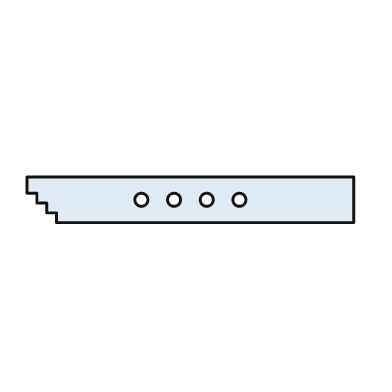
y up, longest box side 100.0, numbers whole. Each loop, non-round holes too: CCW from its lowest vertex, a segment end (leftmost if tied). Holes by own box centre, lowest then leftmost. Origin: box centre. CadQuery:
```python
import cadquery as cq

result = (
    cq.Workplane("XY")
    .moveTo(-41.0, -7.0)
    .lineTo(50.0, -7.0)
    .lineTo(50.0, 7.0)
    .lineTo(-50.0, 7.0)
    .lineTo(-50.0, 2.0)
    .lineTo(-47.0, 2.0)
    .lineTo(-47.0, -1.0)
    .lineTo(-44.0, -1.0)
    .lineTo(-44.0, -4.0)
    .lineTo(-41.0, -4.0)
    .close()
    .moveTo(-15.0, 0.0)
    .circle(2.0)
    .moveTo(-5.0, 0.0)
    .circle(2.0)
    .moveTo(5.0, 0.0)
    .circle(2.0)
    .moveTo(15.0, 0.0)
    .circle(2.0)
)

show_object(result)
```